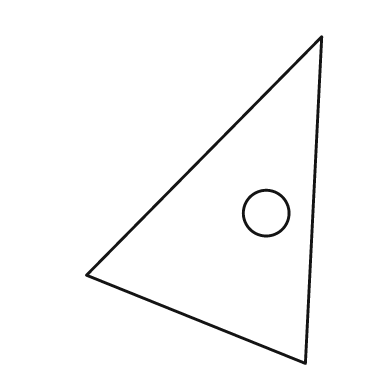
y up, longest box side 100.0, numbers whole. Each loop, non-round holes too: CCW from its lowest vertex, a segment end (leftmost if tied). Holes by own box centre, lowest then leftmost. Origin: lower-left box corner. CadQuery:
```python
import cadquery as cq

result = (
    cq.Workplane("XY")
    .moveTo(67.0, 0.0)
    .lineTo(72.0, 100.0)
    .lineTo(0.0, 27.0)
    .close()
    .moveTo(55.0, 46.0)
    .circle(7.0)
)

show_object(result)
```